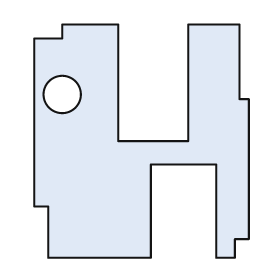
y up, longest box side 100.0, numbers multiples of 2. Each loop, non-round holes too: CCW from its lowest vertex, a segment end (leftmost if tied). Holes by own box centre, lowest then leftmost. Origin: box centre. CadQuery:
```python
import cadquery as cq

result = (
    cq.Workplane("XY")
    .moveTo(-40.0, -50.0)
    .lineTo(4.0, -50.0)
    .lineTo(4.0, -10.0)
    .lineTo(32.0, -10.0)
    .lineTo(32.0, -50.0)
    .lineTo(40.0, -50.0)
    .lineTo(40.0, -42.0)
    .lineTo(46.0, -42.0)
    .lineTo(46.0, 18.0)
    .lineTo(42.0, 18.0)
    .lineTo(42.0, 50.0)
    .lineTo(20.0, 50.0)
    .lineTo(20.0, 0.0)
    .lineTo(-10.0, 0.0)
    .lineTo(-10.0, 50.0)
    .lineTo(-34.0, 50.0)
    .lineTo(-34.0, 44.0)
    .lineTo(-46.0, 44.0)
    .lineTo(-46.0, -28.0)
    .lineTo(-40.0, -28.0)
    .close()
    .moveTo(-34.0, 20.0)
    .circle(8.0)
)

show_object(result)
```